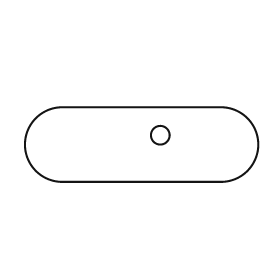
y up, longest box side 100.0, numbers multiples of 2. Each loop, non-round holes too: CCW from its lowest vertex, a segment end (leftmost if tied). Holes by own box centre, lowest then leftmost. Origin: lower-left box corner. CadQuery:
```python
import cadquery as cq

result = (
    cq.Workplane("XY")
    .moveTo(16.0, 0.0)
    .lineTo(84.0, 0.0)
    .threePointArc((100.0, 16.0), (84.0, 32.0))
    .lineTo(16.0, 32.0)
    .threePointArc((0.0, 16.0), (16.0, 0.0))
    .close()
    .moveTo(58.0, 20.0)
    .circle(4.0)
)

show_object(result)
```